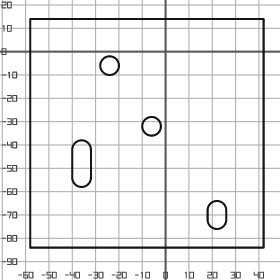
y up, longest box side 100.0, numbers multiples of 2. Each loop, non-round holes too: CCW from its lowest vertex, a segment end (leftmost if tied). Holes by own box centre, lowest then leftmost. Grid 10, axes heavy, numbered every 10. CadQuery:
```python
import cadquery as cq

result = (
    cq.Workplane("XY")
    .moveTo(-58.0, -84.0)
    .lineTo(42.0, -84.0)
    .lineTo(42.0, 14.0)
    .lineTo(-58.0, 14.0)
    .close()
    .moveTo(18.0, -72.0)
    .threePointArc((22.0, -76.0), (26.0, -72.0))
    .lineTo(26.0, -68.0)
    .threePointArc((22.0, -64.0), (18.0, -68.0))
    .close()
    .moveTo(-40.0, -54.0)
    .threePointArc((-36.0, -58.0), (-32.0, -54.0))
    .lineTo(-32.0, -42.0)
    .threePointArc((-36.0, -38.0), (-40.0, -42.0))
    .close()
    .moveTo(-6.0, -32.0)
    .circle(4.0)
    .moveTo(-24.0, -6.0)
    .circle(4.0)
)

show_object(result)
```